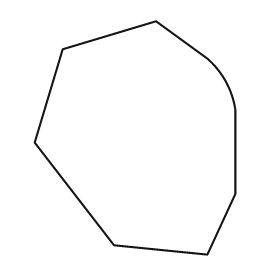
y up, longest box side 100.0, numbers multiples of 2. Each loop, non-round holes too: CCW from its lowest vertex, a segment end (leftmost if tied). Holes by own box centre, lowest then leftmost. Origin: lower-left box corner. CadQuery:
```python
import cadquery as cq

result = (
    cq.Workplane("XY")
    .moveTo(74.0, 0.0)
    .lineTo(86.0, 26.0)
    .lineTo(86.0, 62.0)
    .threePointArc((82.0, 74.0), (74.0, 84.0))
    .lineTo(52.0, 100.0)
    .lineTo(12.0, 88.0)
    .lineTo(0.0, 48.0)
    .lineTo(34.0, 4.0)
    .close()
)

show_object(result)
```